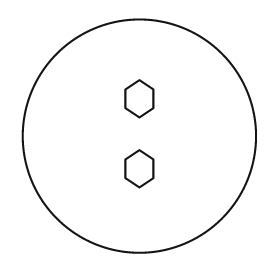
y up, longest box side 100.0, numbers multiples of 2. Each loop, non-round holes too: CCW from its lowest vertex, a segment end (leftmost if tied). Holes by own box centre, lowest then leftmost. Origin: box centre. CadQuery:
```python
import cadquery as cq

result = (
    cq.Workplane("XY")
    .moveTo(0.0, 0.0)
    .circle(50.0)
    .moveTo(0.0, -22.0)
    .lineTo(6.0, -18.0)
    .lineTo(6.0, -10.0)
    .lineTo(0.0, -6.0)
    .lineTo(-6.0, -10.0)
    .lineTo(-6.0, -18.0)
    .close()
    .moveTo(0.0, 8.0)
    .lineTo(6.0, 12.0)
    .lineTo(6.0, 20.0)
    .lineTo(0.0, 24.0)
    .lineTo(-6.0, 20.0)
    .lineTo(-6.0, 12.0)
    .close()
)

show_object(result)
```